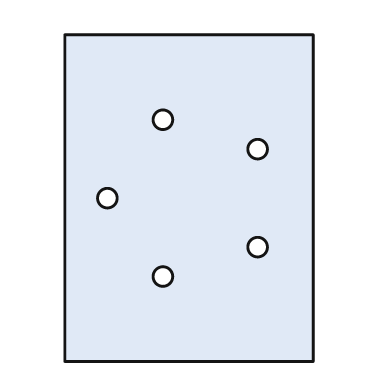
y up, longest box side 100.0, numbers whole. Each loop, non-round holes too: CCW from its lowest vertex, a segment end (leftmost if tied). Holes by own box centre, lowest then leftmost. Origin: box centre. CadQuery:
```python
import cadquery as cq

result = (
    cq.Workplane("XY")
    .moveTo(-38.0, -50.0)
    .lineTo(38.0, -50.0)
    .lineTo(38.0, 50.0)
    .lineTo(-38.0, 50.0)
    .close()
    .moveTo(-8.0, -24.0)
    .circle(3.0)
    .moveTo(21.0, -15.0)
    .circle(3.0)
    .moveTo(-25.0, 0.0)
    .circle(3.0)
    .moveTo(21.0, 15.0)
    .circle(3.0)
    .moveTo(-8.0, 24.0)
    .circle(3.0)
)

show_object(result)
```